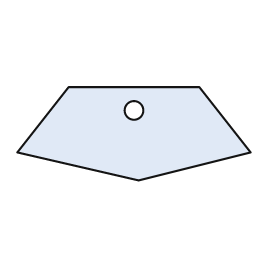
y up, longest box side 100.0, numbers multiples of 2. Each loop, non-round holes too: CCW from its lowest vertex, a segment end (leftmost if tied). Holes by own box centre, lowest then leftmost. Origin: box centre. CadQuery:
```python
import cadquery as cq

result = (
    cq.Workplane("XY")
    .moveTo(2.0, -20.0)
    .lineTo(50.0, -8.0)
    .lineTo(28.0, 20.0)
    .lineTo(-28.0, 20.0)
    .lineTo(-50.0, -8.0)
    .close()
    .moveTo(0.0, 10.0)
    .circle(4.0)
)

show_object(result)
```